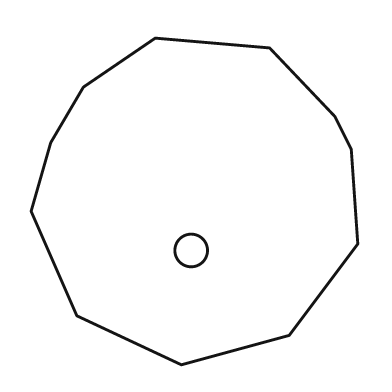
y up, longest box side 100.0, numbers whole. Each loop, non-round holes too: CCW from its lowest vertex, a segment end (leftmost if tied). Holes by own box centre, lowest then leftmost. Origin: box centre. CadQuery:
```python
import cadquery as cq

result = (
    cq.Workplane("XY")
    .moveTo(-4.0, -50.0)
    .lineTo(29.0, -41.0)
    .lineTo(50.0, -13.0)
    .lineTo(48.0, 16.0)
    .lineTo(43.0, 26.0)
    .lineTo(23.0, 47.0)
    .lineTo(-12.0, 50.0)
    .lineTo(-34.0, 35.0)
    .lineTo(-44.0, 18.0)
    .lineTo(-50.0, -3.0)
    .lineTo(-36.0, -35.0)
    .close()
    .moveTo(-1.0, -15.0)
    .circle(5.0)
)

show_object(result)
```